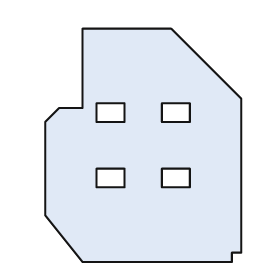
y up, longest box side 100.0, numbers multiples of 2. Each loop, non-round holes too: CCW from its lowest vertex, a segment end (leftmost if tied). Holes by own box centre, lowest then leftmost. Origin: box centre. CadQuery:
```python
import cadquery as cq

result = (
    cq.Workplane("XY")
    .moveTo(-26.0, -50.0)
    .lineTo(38.0, -50.0)
    .lineTo(38.0, -46.0)
    .lineTo(42.0, -46.0)
    .lineTo(42.0, 20.0)
    .lineTo(12.0, 50.0)
    .lineTo(-26.0, 50.0)
    .lineTo(-26.0, 16.0)
    .lineTo(-36.0, 16.0)
    .lineTo(-42.0, 10.0)
    .lineTo(-42.0, -30.0)
    .close()
    .moveTo(-20.0, -18.0)
    .lineTo(-8.0, -18.0)
    .lineTo(-8.0, -10.0)
    .lineTo(-20.0, -10.0)
    .close()
    .moveTo(8.0, -18.0)
    .lineTo(20.0, -18.0)
    .lineTo(20.0, -10.0)
    .lineTo(8.0, -10.0)
    .close()
    .moveTo(-20.0, 10.0)
    .lineTo(-8.0, 10.0)
    .lineTo(-8.0, 18.0)
    .lineTo(-20.0, 18.0)
    .close()
    .moveTo(8.0, 10.0)
    .lineTo(20.0, 10.0)
    .lineTo(20.0, 18.0)
    .lineTo(8.0, 18.0)
    .close()
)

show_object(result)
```